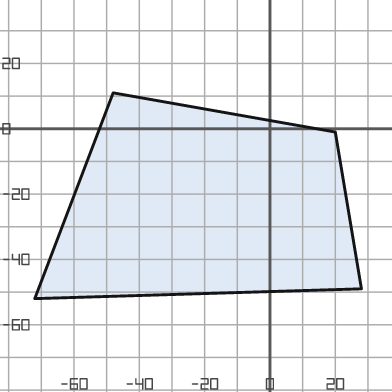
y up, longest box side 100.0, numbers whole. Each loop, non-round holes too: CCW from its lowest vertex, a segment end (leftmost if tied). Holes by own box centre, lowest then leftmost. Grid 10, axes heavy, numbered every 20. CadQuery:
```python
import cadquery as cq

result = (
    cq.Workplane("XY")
    .moveTo(-72.0, -52.0)
    .lineTo(28.0, -49.0)
    .lineTo(20.0, -1.0)
    .lineTo(-48.0, 11.0)
    .close()
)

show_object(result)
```